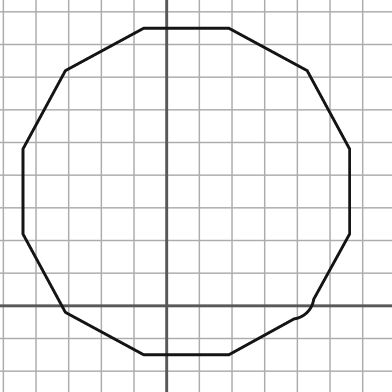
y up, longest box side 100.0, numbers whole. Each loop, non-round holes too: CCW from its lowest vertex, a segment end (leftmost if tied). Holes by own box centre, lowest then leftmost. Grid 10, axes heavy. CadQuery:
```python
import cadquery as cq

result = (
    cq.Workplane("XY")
    .moveTo(-7.0, -15.0)
    .lineTo(19.0, -15.0)
    .lineTo(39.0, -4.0)
    .threePointArc((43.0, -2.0), (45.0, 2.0))
    .lineTo(56.0, 22.0)
    .lineTo(56.0, 48.0)
    .lineTo(43.0, 72.0)
    .lineTo(19.0, 85.0)
    .lineTo(-7.0, 85.0)
    .lineTo(-31.0, 72.0)
    .lineTo(-44.0, 48.0)
    .lineTo(-44.0, 22.0)
    .lineTo(-31.0, -2.0)
    .close()
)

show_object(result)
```